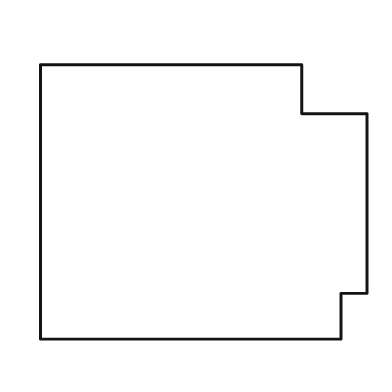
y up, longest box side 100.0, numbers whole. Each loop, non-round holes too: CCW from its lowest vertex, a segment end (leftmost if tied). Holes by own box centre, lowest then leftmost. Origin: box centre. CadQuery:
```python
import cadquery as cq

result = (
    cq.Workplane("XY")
    .moveTo(-50.0, -42.0)
    .lineTo(42.0, -42.0)
    .lineTo(42.0, -28.0)
    .lineTo(50.0, -28.0)
    .lineTo(50.0, 27.0)
    .lineTo(30.0, 27.0)
    .lineTo(30.0, 42.0)
    .lineTo(-50.0, 42.0)
    .close()
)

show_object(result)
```